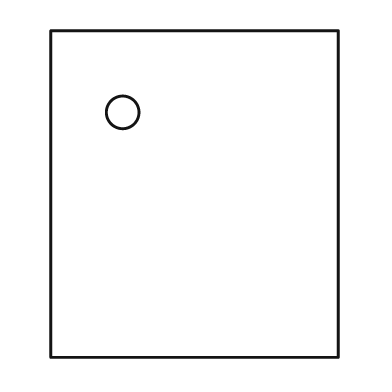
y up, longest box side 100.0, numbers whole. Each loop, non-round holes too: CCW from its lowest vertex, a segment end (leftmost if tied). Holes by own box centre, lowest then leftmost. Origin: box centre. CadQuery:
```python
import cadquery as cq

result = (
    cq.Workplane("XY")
    .moveTo(-44.0, -50.0)
    .lineTo(44.0, -50.0)
    .lineTo(44.0, 50.0)
    .lineTo(-44.0, 50.0)
    .close()
    .moveTo(-22.0, 25.0)
    .circle(5.0)
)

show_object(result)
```